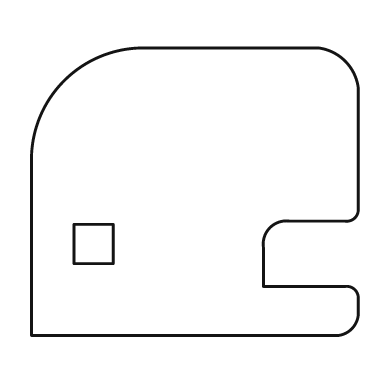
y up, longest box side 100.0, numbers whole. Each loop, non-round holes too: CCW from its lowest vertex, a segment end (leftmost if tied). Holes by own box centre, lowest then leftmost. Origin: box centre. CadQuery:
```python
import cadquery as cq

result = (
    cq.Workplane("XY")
    .moveTo(-50.0, -44.0)
    .lineTo(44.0, -44.0)
    .threePointArc((48.0, -42.0), (50.0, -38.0))
    .lineTo(50.0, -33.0)
    .threePointArc((49.0, -30.0), (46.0, -29.0))
    .lineTo(21.0, -29.0)
    .lineTo(21.0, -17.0)
    .threePointArc((23.0, -11.0), (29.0, -9.0))
    .lineTo(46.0, -9.0)
    .threePointArc((49.0, -8.0), (50.0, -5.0))
    .lineTo(50.0, 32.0)
    .threePointArc((46.0, 40.0), (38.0, 44.0))
    .lineTo(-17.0, 44.0)
    .threePointArc((-40.0, 34.0), (-50.0, 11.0))
    .close()
    .moveTo(-37.0, -22.0)
    .lineTo(-25.0, -22.0)
    .lineTo(-25.0, -10.0)
    .lineTo(-37.0, -10.0)
    .close()
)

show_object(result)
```